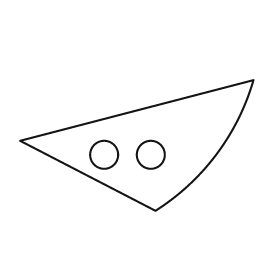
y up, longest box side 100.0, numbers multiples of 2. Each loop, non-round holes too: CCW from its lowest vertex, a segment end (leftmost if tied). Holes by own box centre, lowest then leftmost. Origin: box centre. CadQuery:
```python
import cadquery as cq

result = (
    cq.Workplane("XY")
    .moveTo(8.0, -28.0)
    .threePointArc((34.0, -4.0), (50.0, 28.0))
    .lineTo(-50.0, 2.0)
    .close()
    .moveTo(-14.0, -4.0)
    .circle(6.0)
    .moveTo(6.0, -4.0)
    .circle(6.0)
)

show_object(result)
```